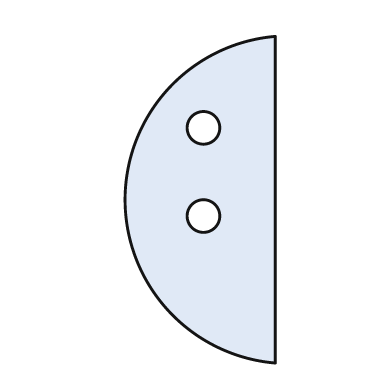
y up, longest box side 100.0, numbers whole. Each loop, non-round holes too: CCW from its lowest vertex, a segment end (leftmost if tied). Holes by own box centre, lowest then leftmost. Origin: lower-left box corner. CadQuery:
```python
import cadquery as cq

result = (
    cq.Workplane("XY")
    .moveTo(46.0, 0.0)
    .lineTo(46.0, 100.0)
    .threePointArc((0.0, 50.0), (46.0, 0.0))
    .close()
    .moveTo(24.0, 45.0)
    .circle(5.0)
    .moveTo(24.0, 72.0)
    .circle(5.0)
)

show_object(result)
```